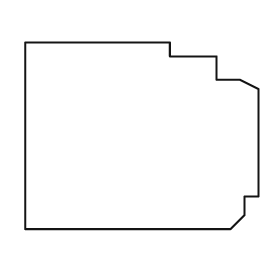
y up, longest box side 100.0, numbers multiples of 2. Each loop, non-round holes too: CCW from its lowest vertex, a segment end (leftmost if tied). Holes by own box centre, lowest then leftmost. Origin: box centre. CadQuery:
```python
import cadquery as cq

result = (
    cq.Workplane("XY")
    .moveTo(-50.0, -40.0)
    .lineTo(38.0, -40.0)
    .lineTo(44.0, -34.0)
    .lineTo(44.0, -26.0)
    .lineTo(50.0, -26.0)
    .lineTo(50.0, 20.0)
    .lineTo(42.0, 24.0)
    .lineTo(32.0, 24.0)
    .lineTo(32.0, 34.0)
    .lineTo(12.0, 34.0)
    .lineTo(12.0, 40.0)
    .lineTo(-50.0, 40.0)
    .close()
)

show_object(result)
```